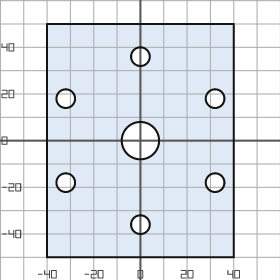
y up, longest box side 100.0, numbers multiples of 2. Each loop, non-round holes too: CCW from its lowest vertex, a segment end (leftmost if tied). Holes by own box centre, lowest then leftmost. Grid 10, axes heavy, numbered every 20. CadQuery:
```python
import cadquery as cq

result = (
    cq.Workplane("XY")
    .moveTo(-40.0, -50.0)
    .lineTo(40.0, -50.0)
    .lineTo(40.0, 50.0)
    .lineTo(-40.0, 50.0)
    .close()
    .moveTo(0.0, -36.0)
    .circle(4.0)
    .moveTo(-32.0, -18.0)
    .circle(4.0)
    .moveTo(32.0, -18.0)
    .circle(4.0)
    .moveTo(0.0, 0.0)
    .circle(8.0)
    .moveTo(-32.0, 18.0)
    .circle(4.0)
    .moveTo(32.0, 18.0)
    .circle(4.0)
    .moveTo(0.0, 36.0)
    .circle(4.0)
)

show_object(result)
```